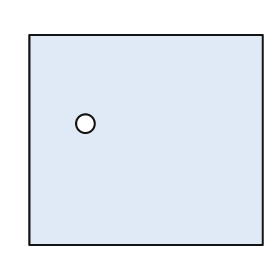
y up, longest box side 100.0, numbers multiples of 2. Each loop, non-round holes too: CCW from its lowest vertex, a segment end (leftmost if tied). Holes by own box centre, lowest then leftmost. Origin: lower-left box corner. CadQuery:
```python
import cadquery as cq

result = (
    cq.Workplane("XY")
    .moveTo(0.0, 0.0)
    .lineTo(100.0, 0.0)
    .lineTo(100.0, 90.0)
    .lineTo(0.0, 90.0)
    .close()
    .moveTo(24.0, 52.0)
    .circle(4.0)
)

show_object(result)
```